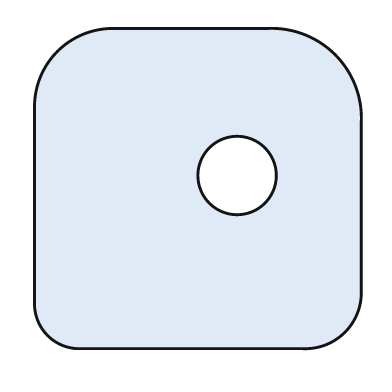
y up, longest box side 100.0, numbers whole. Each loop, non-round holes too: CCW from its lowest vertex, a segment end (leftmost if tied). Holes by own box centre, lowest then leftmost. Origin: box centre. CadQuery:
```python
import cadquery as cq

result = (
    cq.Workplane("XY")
    .moveTo(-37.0, -49.0)
    .lineTo(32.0, -49.0)
    .threePointArc((45.0, -44.0), (50.0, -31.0))
    .lineTo(50.0, 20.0)
    .threePointArc((42.0, 41.0), (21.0, 49.0))
    .lineTo(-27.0, 49.0)
    .threePointArc((-43.0, 42.0), (-50.0, 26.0))
    .lineTo(-50.0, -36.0)
    .threePointArc((-46.0, -45.0), (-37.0, -49.0))
    .close()
    .moveTo(12.0, 4.0)
    .circle(12.0)
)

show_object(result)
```